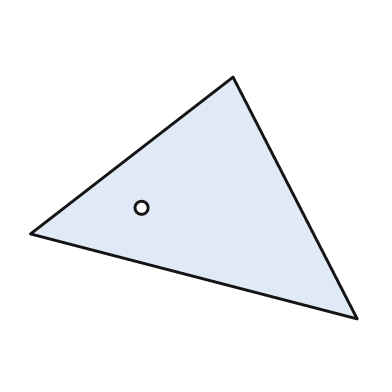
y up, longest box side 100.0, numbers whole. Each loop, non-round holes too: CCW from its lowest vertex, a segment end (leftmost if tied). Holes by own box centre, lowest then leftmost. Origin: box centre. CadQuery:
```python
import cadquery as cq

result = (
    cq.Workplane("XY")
    .moveTo(50.0, -37.0)
    .lineTo(12.0, 37.0)
    .lineTo(-50.0, -11.0)
    .close()
    .moveTo(-16.0, -3.0)
    .circle(2.0)
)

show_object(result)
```